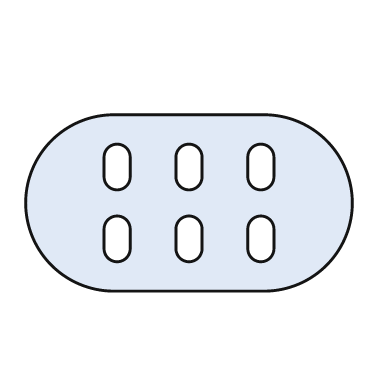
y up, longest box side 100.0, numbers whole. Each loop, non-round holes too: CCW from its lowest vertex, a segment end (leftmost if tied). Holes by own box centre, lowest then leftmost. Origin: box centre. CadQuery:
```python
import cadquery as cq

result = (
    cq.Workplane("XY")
    .moveTo(-23.0, -27.0)
    .lineTo(23.0, -27.0)
    .threePointArc((50.0, 0.0), (23.0, 27.0))
    .lineTo(-23.0, 27.0)
    .threePointArc((-50.0, 0.0), (-23.0, -27.0))
    .close()
    .moveTo(-26.0, -14.0)
    .threePointArc((-22.0, -18.0), (-18.0, -14.0))
    .lineTo(-18.0, -8.0)
    .threePointArc((-22.0, -4.0), (-26.0, -8.0))
    .close()
    .moveTo(-4.0, -14.0)
    .threePointArc((0.0, -18.0), (4.0, -14.0))
    .lineTo(4.0, -8.0)
    .threePointArc((0.0, -4.0), (-4.0, -8.0))
    .close()
    .moveTo(18.0, -14.0)
    .threePointArc((22.0, -18.0), (26.0, -14.0))
    .lineTo(26.0, -8.0)
    .threePointArc((22.0, -4.0), (18.0, -8.0))
    .close()
    .moveTo(-26.0, 8.0)
    .threePointArc((-22.0, 4.0), (-18.0, 8.0))
    .lineTo(-18.0, 14.0)
    .threePointArc((-22.0, 18.0), (-26.0, 14.0))
    .close()
    .moveTo(-4.0, 8.0)
    .threePointArc((0.0, 4.0), (4.0, 8.0))
    .lineTo(4.0, 14.0)
    .threePointArc((0.0, 18.0), (-4.0, 14.0))
    .close()
    .moveTo(18.0, 8.0)
    .threePointArc((22.0, 4.0), (26.0, 8.0))
    .lineTo(26.0, 14.0)
    .threePointArc((22.0, 18.0), (18.0, 14.0))
    .close()
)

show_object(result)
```